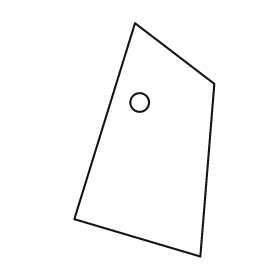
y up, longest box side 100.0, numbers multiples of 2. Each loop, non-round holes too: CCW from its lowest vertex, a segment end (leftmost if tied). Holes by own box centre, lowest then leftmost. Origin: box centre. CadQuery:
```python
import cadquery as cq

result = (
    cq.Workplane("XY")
    .moveTo(24.0, -50.0)
    .lineTo(30.0, 24.0)
    .lineTo(-4.0, 50.0)
    .lineTo(-30.0, -34.0)
    .close()
    .moveTo(-2.0, 16.0)
    .circle(4.0)
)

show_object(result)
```